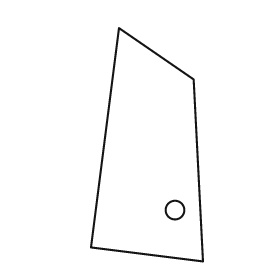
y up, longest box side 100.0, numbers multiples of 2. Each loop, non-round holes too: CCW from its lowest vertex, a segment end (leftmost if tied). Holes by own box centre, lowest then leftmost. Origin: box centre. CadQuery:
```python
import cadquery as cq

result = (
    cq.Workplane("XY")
    .moveTo(24.0, -50.0)
    .lineTo(20.0, 28.0)
    .lineTo(-12.0, 50.0)
    .lineTo(-24.0, -44.0)
    .close()
    .moveTo(12.0, -28.0)
    .circle(4.0)
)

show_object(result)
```